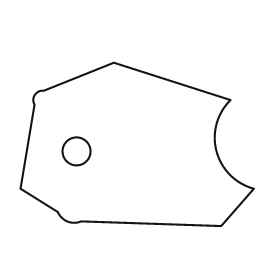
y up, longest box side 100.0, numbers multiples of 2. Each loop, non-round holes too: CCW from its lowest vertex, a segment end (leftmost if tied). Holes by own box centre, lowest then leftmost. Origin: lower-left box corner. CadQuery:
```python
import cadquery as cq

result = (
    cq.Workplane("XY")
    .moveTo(86.0, 0.0)
    .lineTo(100.0, 16.0)
    .threePointArc((84.0, 32.0), (90.0, 54.0))
    .lineTo(40.0, 70.0)
    .lineTo(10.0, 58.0)
    .threePointArc((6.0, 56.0), (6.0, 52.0))
    .lineTo(0.0, 16.0)
    .lineTo(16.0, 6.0)
    .threePointArc((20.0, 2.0), (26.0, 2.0))
    .close()
    .moveTo(24.0, 32.0)
    .circle(6.0)
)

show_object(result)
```